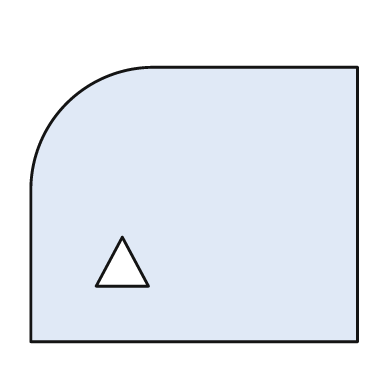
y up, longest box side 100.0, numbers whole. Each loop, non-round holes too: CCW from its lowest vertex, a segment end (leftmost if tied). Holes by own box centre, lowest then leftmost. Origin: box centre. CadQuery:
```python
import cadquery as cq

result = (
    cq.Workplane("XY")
    .moveTo(-50.0, -42.0)
    .lineTo(50.0, -42.0)
    .lineTo(50.0, 42.0)
    .lineTo(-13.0, 42.0)
    .threePointArc((-39.0, 31.0), (-50.0, 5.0))
    .close()
    .moveTo(-30.0, -25.0)
    .lineTo(-14.0, -25.0)
    .lineTo(-22.0, -10.0)
    .close()
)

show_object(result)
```